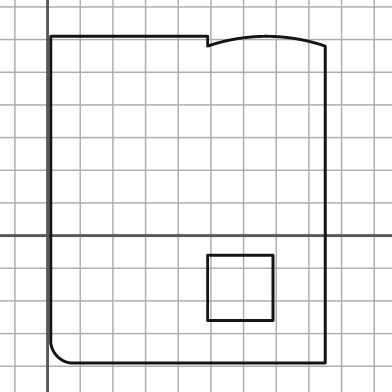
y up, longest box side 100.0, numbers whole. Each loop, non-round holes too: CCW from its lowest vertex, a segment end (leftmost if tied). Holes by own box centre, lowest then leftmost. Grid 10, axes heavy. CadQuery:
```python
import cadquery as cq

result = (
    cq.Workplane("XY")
    .moveTo(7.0, -39.0)
    .lineTo(85.0, -39.0)
    .lineTo(85.0, 58.0)
    .threePointArc((67.0, 61.0), (49.0, 58.0))
    .lineTo(49.0, 61.0)
    .lineTo(1.0, 61.0)
    .lineTo(1.0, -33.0)
    .threePointArc((3.0, -37.0), (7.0, -39.0))
    .close()
    .moveTo(49.0, -26.0)
    .lineTo(69.0, -26.0)
    .lineTo(69.0, -6.0)
    .lineTo(49.0, -6.0)
    .close()
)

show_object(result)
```